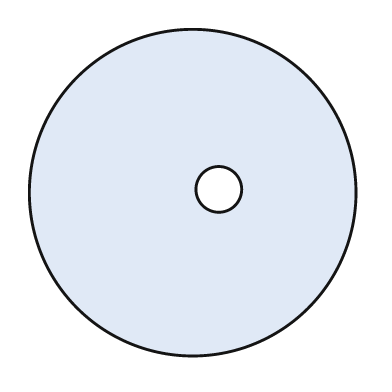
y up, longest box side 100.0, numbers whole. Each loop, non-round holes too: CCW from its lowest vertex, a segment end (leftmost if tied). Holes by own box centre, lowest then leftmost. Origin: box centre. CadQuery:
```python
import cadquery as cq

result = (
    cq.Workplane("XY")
    .moveTo(0.0, 0.0)
    .circle(50.0)
    .moveTo(8.0, 1.0)
    .circle(7.0)
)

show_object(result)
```